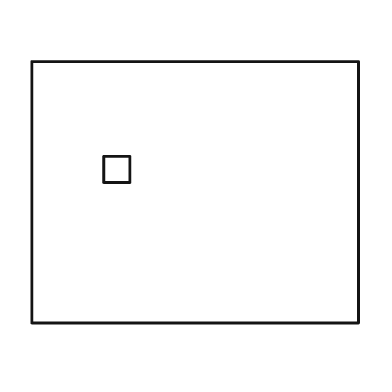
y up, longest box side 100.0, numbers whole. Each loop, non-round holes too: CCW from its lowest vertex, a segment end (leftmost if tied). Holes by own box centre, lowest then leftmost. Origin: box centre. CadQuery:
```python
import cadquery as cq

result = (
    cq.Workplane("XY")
    .moveTo(-50.0, -40.0)
    .lineTo(50.0, -40.0)
    .lineTo(50.0, 40.0)
    .lineTo(-50.0, 40.0)
    .close()
    .moveTo(-28.0, 3.0)
    .lineTo(-20.0, 3.0)
    .lineTo(-20.0, 11.0)
    .lineTo(-28.0, 11.0)
    .close()
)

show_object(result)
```